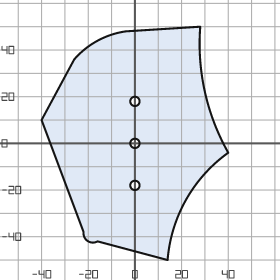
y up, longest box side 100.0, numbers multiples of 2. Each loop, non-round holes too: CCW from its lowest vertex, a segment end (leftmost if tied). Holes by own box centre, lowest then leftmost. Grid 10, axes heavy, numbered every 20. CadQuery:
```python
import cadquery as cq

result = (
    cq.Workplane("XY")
    .moveTo(14.0, -50.0)
    .threePointArc((22.0, -24.0), (40.0, -4.0))
    .threePointArc((30.0, 22.0), (28.0, 50.0))
    .lineTo(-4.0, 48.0)
    .threePointArc((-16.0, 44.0), (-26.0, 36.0))
    .lineTo(-40.0, 10.0)
    .lineTo(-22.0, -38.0)
    .threePointArc((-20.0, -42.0), (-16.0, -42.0))
    .close()
    .moveTo(0.0, -18.0)
    .circle(2.0)
    .moveTo(0.0, 0.0)
    .circle(2.0)
    .moveTo(0.0, 18.0)
    .circle(2.0)
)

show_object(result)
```